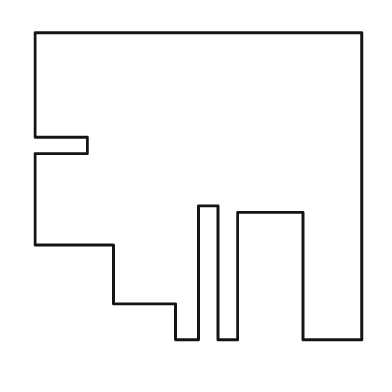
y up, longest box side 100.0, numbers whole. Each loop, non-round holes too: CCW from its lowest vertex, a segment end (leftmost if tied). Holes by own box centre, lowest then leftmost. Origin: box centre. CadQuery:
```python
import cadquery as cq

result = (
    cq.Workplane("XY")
    .moveTo(-7.0, -47.0)
    .lineTo(0.0, -47.0)
    .lineTo(0.0, -6.0)
    .lineTo(6.0, -6.0)
    .lineTo(6.0, -47.0)
    .lineTo(12.0, -47.0)
    .lineTo(12.0, -8.0)
    .lineTo(32.0, -8.0)
    .lineTo(32.0, -47.0)
    .lineTo(50.0, -47.0)
    .lineTo(50.0, 47.0)
    .lineTo(-50.0, 47.0)
    .lineTo(-50.0, 15.0)
    .lineTo(-34.0, 15.0)
    .lineTo(-34.0, 10.0)
    .lineTo(-50.0, 10.0)
    .lineTo(-50.0, -18.0)
    .lineTo(-26.0, -18.0)
    .lineTo(-26.0, -36.0)
    .lineTo(-7.0, -36.0)
    .close()
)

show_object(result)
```